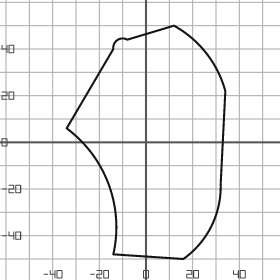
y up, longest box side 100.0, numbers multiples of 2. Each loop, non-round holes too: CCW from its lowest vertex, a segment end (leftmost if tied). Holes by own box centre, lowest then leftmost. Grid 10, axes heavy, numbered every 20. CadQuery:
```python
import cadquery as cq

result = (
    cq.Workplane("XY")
    .moveTo(16.0, -50.0)
    .threePointArc((28.0, -36.0), (32.0, -18.0))
    .lineTo(34.0, 22.0)
    .threePointArc((26.0, 38.0), (12.0, 50.0))
    .lineTo(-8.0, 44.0)
    .threePointArc((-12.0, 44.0), (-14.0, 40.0))
    .lineTo(-34.0, 6.0)
    .threePointArc((-16.0, -18.0), (-14.0, -48.0))
    .close()
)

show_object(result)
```